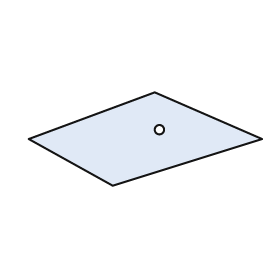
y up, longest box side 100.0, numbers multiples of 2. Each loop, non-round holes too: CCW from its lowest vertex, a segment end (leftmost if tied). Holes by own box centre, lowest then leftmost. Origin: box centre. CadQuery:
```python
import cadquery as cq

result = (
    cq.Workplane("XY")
    .moveTo(-14.0, -20.0)
    .lineTo(50.0, 0.0)
    .lineTo(4.0, 20.0)
    .lineTo(-50.0, 0.0)
    .close()
    .moveTo(6.0, 4.0)
    .circle(2.0)
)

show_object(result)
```